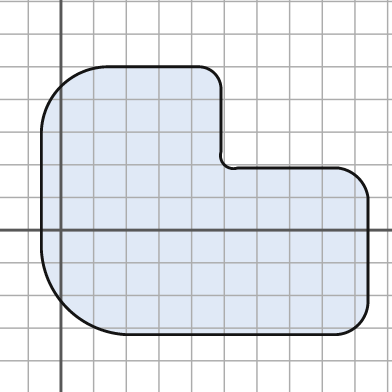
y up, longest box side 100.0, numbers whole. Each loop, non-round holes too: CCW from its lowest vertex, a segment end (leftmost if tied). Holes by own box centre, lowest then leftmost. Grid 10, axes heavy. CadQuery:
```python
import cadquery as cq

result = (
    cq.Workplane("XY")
    .moveTo(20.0, -32.0)
    .lineTo(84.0, -32.0)
    .threePointArc((91.0, -29.0), (94.0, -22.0))
    .lineTo(94.0, 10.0)
    .threePointArc((91.0, 16.0), (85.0, 19.0))
    .lineTo(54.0, 19.0)
    .threePointArc((50.0, 20.0), (49.0, 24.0))
    .lineTo(49.0, 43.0)
    .threePointArc((47.0, 48.0), (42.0, 50.0))
    .lineTo(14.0, 50.0)
    .threePointArc((0.0, 44.0), (-6.0, 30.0))
    .lineTo(-6.0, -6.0)
    .threePointArc((2.0, -24.0), (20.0, -32.0))
    .close()
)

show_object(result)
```